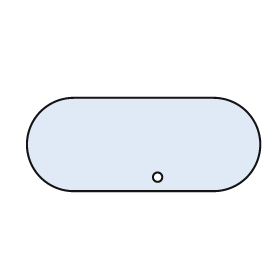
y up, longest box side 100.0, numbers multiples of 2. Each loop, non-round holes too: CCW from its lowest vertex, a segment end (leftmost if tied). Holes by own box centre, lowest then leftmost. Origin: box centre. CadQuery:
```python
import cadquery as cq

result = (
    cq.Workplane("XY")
    .moveTo(-30.0, -20.0)
    .lineTo(30.0, -20.0)
    .threePointArc((50.0, 0.0), (30.0, 20.0))
    .lineTo(-30.0, 20.0)
    .threePointArc((-50.0, 0.0), (-30.0, -20.0))
    .close()
    .moveTo(6.0, -14.0)
    .circle(2.0)
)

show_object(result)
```